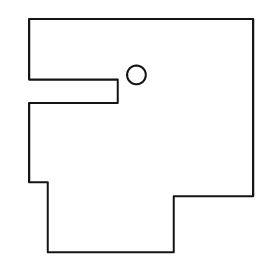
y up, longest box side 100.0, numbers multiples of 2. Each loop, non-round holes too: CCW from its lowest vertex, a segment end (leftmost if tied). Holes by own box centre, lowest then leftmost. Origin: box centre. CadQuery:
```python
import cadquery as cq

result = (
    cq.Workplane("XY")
    .moveTo(-40.0, -50.0)
    .lineTo(14.0, -50.0)
    .lineTo(14.0, -26.0)
    .lineTo(48.0, -26.0)
    .lineTo(48.0, 50.0)
    .lineTo(-48.0, 50.0)
    .lineTo(-48.0, 24.0)
    .lineTo(-10.0, 24.0)
    .lineTo(-10.0, 14.0)
    .lineTo(-48.0, 14.0)
    .lineTo(-48.0, -20.0)
    .lineTo(-40.0, -20.0)
    .close()
    .moveTo(-2.0, 26.0)
    .circle(4.0)
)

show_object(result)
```